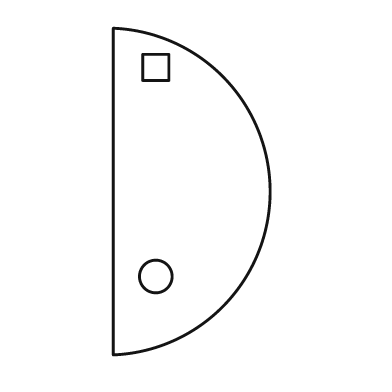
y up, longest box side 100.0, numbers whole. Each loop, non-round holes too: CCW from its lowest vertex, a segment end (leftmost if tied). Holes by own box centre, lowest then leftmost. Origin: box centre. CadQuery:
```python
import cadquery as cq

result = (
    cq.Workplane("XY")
    .moveTo(-24.0, -50.0)
    .threePointArc((24.0, 0.0), (-24.0, 50.0))
    .close()
    .moveTo(-11.0, -26.0)
    .circle(5.0)
    .moveTo(-15.0, 34.0)
    .lineTo(-7.0, 34.0)
    .lineTo(-7.0, 42.0)
    .lineTo(-15.0, 42.0)
    .close()
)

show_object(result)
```